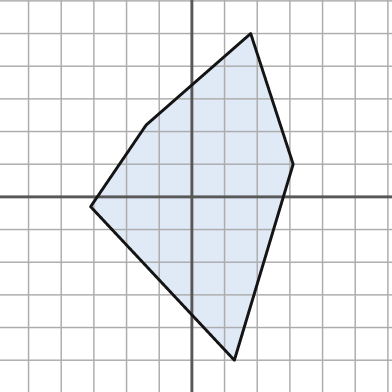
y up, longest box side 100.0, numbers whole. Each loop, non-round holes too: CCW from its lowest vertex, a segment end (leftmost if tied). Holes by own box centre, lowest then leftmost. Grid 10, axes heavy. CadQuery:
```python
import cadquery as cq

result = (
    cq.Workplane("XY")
    .moveTo(13.0, -50.0)
    .lineTo(31.0, 10.0)
    .lineTo(18.0, 50.0)
    .lineTo(-14.0, 22.0)
    .lineTo(-31.0, -3.0)
    .close()
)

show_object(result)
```